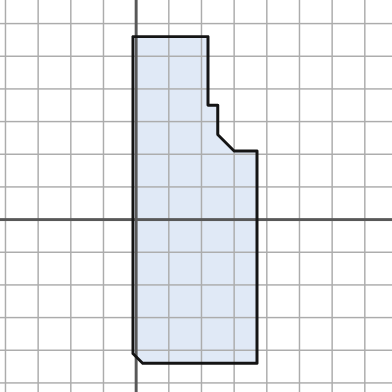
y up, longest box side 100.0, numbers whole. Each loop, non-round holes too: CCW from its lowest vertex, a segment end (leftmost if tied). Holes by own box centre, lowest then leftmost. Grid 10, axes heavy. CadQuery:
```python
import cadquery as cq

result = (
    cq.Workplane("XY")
    .moveTo(2.0, -44.0)
    .lineTo(37.0, -44.0)
    .lineTo(37.0, 21.0)
    .lineTo(30.0, 21.0)
    .lineTo(25.0, 26.0)
    .lineTo(25.0, 35.0)
    .lineTo(22.0, 35.0)
    .lineTo(22.0, 56.0)
    .lineTo(-1.0, 56.0)
    .lineTo(-1.0, -41.0)
    .close()
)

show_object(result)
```